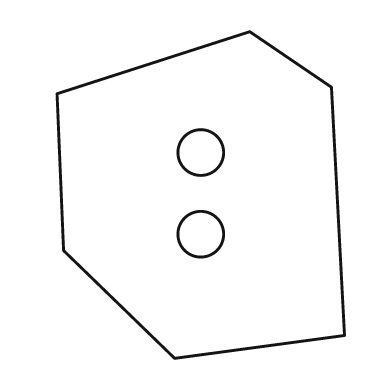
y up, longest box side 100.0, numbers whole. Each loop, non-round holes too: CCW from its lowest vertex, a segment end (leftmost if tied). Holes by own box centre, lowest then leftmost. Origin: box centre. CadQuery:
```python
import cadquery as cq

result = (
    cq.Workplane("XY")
    .moveTo(-8.0, -50.0)
    .lineTo(44.0, -43.0)
    .lineTo(40.0, 33.0)
    .lineTo(15.0, 50.0)
    .lineTo(-44.0, 31.0)
    .lineTo(-42.0, -17.0)
    .close()
    .moveTo(0.0, -12.0)
    .circle(7.0)
    .moveTo(0.0, 13.0)
    .circle(7.0)
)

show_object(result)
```